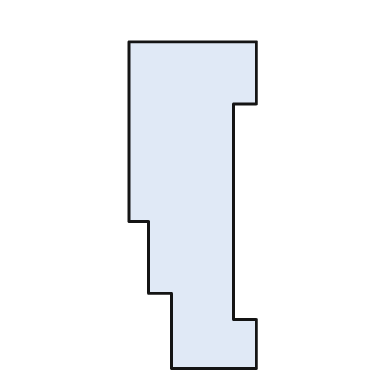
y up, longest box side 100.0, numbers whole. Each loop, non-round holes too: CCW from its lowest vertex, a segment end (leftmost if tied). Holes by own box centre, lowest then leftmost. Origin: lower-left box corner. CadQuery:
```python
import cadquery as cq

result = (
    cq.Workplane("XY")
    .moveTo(13.0, 0.0)
    .lineTo(39.0, 0.0)
    .lineTo(39.0, 15.0)
    .lineTo(32.0, 15.0)
    .lineTo(32.0, 81.0)
    .lineTo(39.0, 81.0)
    .lineTo(39.0, 100.0)
    .lineTo(0.0, 100.0)
    .lineTo(0.0, 45.0)
    .lineTo(6.0, 45.0)
    .lineTo(6.0, 23.0)
    .lineTo(13.0, 23.0)
    .close()
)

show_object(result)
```